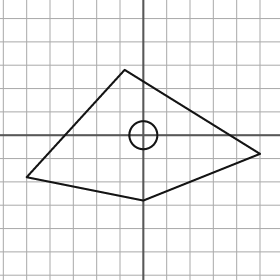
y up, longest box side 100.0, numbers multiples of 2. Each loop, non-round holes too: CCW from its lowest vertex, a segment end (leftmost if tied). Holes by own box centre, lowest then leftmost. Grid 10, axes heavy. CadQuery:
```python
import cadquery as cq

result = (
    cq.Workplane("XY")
    .moveTo(0.0, -28.0)
    .lineTo(50.0, -8.0)
    .lineTo(-8.0, 28.0)
    .lineTo(-50.0, -18.0)
    .close()
    .moveTo(0.0, 0.0)
    .circle(6.0)
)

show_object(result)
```